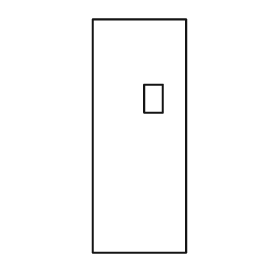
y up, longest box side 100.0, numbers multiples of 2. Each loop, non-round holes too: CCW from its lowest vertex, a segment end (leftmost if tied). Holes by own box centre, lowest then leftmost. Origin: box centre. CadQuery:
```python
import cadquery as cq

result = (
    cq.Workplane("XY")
    .moveTo(-20.0, -50.0)
    .lineTo(20.0, -50.0)
    .lineTo(20.0, 50.0)
    .lineTo(-20.0, 50.0)
    .close()
    .moveTo(2.0, 10.0)
    .lineTo(10.0, 10.0)
    .lineTo(10.0, 22.0)
    .lineTo(2.0, 22.0)
    .close()
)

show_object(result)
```